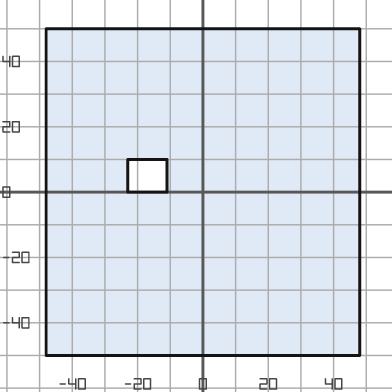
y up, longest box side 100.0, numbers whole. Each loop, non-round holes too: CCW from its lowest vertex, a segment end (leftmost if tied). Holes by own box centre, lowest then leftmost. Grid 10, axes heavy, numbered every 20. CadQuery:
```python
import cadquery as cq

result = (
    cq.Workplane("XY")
    .moveTo(-48.0, -50.0)
    .lineTo(48.0, -50.0)
    .lineTo(48.0, 50.0)
    .lineTo(-48.0, 50.0)
    .close()
    .moveTo(-23.0, 0.0)
    .lineTo(-11.0, 0.0)
    .lineTo(-11.0, 10.0)
    .lineTo(-23.0, 10.0)
    .close()
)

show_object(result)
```